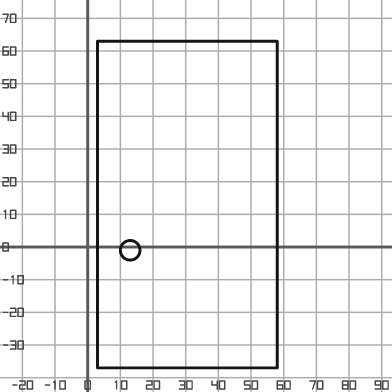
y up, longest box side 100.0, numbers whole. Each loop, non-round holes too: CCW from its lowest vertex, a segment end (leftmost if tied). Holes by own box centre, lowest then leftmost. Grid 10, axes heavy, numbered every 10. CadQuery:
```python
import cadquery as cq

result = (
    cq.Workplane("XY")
    .moveTo(3.0, -37.0)
    .lineTo(58.0, -37.0)
    .lineTo(58.0, 63.0)
    .lineTo(3.0, 63.0)
    .close()
    .moveTo(13.0, -1.0)
    .circle(3.0)
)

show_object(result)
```